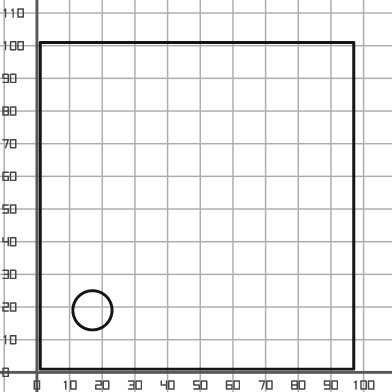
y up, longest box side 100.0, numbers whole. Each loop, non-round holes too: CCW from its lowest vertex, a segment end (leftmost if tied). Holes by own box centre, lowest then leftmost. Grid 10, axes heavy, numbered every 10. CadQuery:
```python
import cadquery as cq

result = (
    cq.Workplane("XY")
    .moveTo(1.0, 1.0)
    .lineTo(97.0, 1.0)
    .lineTo(97.0, 101.0)
    .lineTo(1.0, 101.0)
    .close()
    .moveTo(17.0, 19.0)
    .circle(6.0)
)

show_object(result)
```